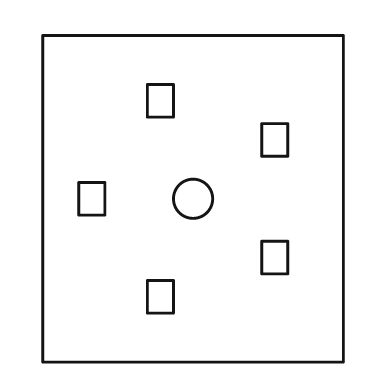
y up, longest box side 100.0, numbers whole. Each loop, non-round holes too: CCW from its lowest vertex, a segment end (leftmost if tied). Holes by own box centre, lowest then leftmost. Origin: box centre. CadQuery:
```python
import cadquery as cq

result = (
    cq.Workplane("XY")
    .moveTo(-46.0, -50.0)
    .lineTo(46.0, -50.0)
    .lineTo(46.0, 50.0)
    .lineTo(-46.0, 50.0)
    .close()
    .moveTo(-14.0, -35.0)
    .lineTo(-6.0, -35.0)
    .lineTo(-6.0, -25.0)
    .lineTo(-14.0, -25.0)
    .close()
    .moveTo(21.0, -23.0)
    .lineTo(29.0, -23.0)
    .lineTo(29.0, -13.0)
    .lineTo(21.0, -13.0)
    .close()
    .moveTo(-35.0, -5.0)
    .lineTo(-27.0, -5.0)
    .lineTo(-27.0, 5.0)
    .lineTo(-35.0, 5.0)
    .close()
    .moveTo(0.0, 0.0)
    .circle(6.0)
    .moveTo(21.0, 13.0)
    .lineTo(29.0, 13.0)
    .lineTo(29.0, 23.0)
    .lineTo(21.0, 23.0)
    .close()
    .moveTo(-14.0, 25.0)
    .lineTo(-6.0, 25.0)
    .lineTo(-6.0, 35.0)
    .lineTo(-14.0, 35.0)
    .close()
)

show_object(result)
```